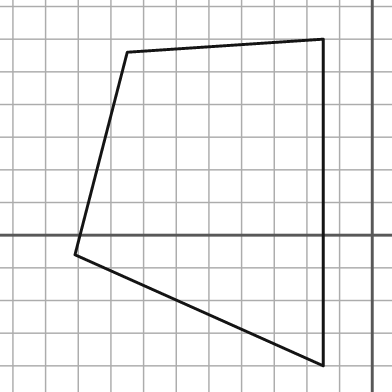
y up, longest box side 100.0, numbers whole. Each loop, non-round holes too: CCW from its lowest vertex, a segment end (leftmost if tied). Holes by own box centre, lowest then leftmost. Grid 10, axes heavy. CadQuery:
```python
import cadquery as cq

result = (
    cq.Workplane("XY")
    .moveTo(-15.0, -40.0)
    .lineTo(-15.0, 60.0)
    .lineTo(-75.0, 56.0)
    .lineTo(-91.0, -6.0)
    .close()
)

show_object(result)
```